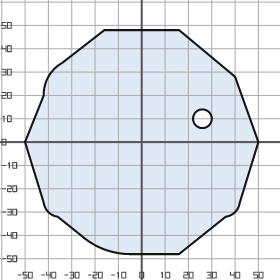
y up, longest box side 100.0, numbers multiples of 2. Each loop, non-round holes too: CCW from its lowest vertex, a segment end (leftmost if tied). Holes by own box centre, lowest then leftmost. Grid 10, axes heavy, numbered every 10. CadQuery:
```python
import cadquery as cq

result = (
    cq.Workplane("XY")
    .moveTo(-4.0, -48.0)
    .lineTo(16.0, -48.0)
    .lineTo(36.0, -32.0)
    .threePointArc((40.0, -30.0), (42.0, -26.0))
    .lineTo(50.0, 0.0)
    .lineTo(40.0, 28.0)
    .lineTo(16.0, 48.0)
    .lineTo(-16.0, 48.0)
    .lineTo(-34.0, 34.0)
    .threePointArc((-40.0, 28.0), (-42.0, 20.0))
    .lineTo(-50.0, 0.0)
    .lineTo(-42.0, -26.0)
    .threePointArc((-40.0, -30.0), (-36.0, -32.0))
    .lineTo(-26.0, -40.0)
    .threePointArc((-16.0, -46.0), (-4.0, -48.0))
    .close()
    .moveTo(26.0, 10.0)
    .circle(4.0)
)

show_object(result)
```